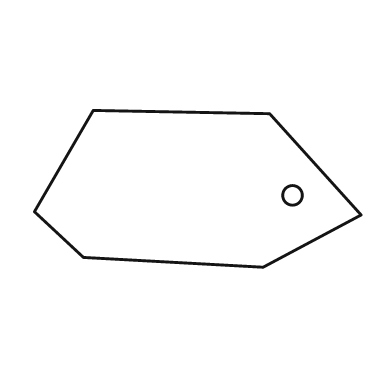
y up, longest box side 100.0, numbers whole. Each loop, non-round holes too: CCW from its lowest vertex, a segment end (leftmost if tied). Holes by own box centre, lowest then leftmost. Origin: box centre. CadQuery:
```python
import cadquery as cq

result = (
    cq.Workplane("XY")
    .moveTo(20.0, -24.0)
    .lineTo(50.0, -8.0)
    .lineTo(22.0, 23.0)
    .lineTo(-32.0, 24.0)
    .lineTo(-50.0, -7.0)
    .lineTo(-35.0, -21.0)
    .close()
    .moveTo(29.0, -2.0)
    .circle(3.0)
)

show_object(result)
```